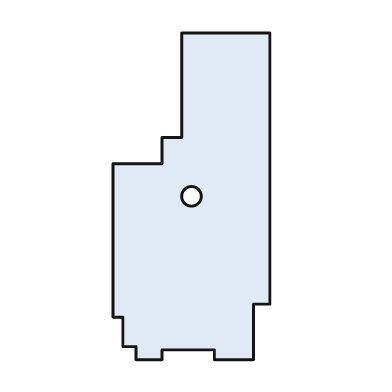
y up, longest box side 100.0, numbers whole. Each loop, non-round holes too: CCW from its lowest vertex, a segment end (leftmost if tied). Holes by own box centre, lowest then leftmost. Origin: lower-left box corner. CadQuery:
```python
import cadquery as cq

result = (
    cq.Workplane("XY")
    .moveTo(7.0, 0.0)
    .lineTo(15.0, 0.0)
    .lineTo(15.0, 3.0)
    .lineTo(31.0, 3.0)
    .lineTo(31.0, 0.0)
    .lineTo(43.0, 0.0)
    .lineTo(43.0, 17.0)
    .lineTo(48.0, 17.0)
    .lineTo(48.0, 100.0)
    .lineTo(21.0, 100.0)
    .lineTo(21.0, 68.0)
    .lineTo(15.0, 68.0)
    .lineTo(15.0, 60.0)
    .lineTo(0.0, 60.0)
    .lineTo(0.0, 13.0)
    .lineTo(3.0, 13.0)
    .lineTo(3.0, 4.0)
    .lineTo(7.0, 4.0)
    .close()
    .moveTo(24.0, 50.0)
    .circle(3.0)
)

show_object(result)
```